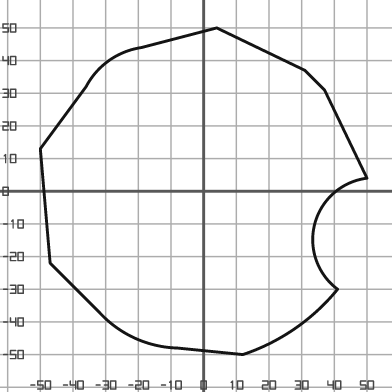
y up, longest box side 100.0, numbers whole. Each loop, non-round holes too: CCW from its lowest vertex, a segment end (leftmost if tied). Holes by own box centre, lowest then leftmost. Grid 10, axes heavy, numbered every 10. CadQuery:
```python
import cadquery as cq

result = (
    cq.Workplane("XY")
    .moveTo(12.0, -50.0)
    .threePointArc((28.0, -42.0), (41.0, -30.0))
    .threePointArc((34.0, -10.0), (50.0, 4.0))
    .lineTo(37.0, 31.0)
    .lineTo(31.0, 37.0)
    .lineTo(4.0, 50.0)
    .lineTo(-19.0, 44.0)
    .threePointArc((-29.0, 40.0), (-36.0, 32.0))
    .lineTo(-50.0, 13.0)
    .lineTo(-47.0, -22.0)
    .lineTo(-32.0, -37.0)
    .threePointArc((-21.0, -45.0), (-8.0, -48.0))
    .close()
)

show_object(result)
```